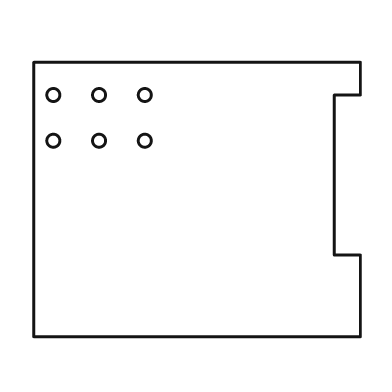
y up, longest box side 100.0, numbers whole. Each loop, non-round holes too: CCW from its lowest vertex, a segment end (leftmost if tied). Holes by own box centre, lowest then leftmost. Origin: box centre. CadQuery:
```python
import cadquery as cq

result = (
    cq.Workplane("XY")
    .moveTo(-50.0, -42.0)
    .lineTo(50.0, -42.0)
    .lineTo(50.0, -17.0)
    .lineTo(42.0, -17.0)
    .lineTo(42.0, 32.0)
    .lineTo(50.0, 32.0)
    .lineTo(50.0, 42.0)
    .lineTo(-50.0, 42.0)
    .close()
    .moveTo(-44.0, 18.0)
    .circle(2.0)
    .moveTo(-30.0, 18.0)
    .circle(2.0)
    .moveTo(-16.0, 18.0)
    .circle(2.0)
    .moveTo(-44.0, 32.0)
    .circle(2.0)
    .moveTo(-30.0, 32.0)
    .circle(2.0)
    .moveTo(-16.0, 32.0)
    .circle(2.0)
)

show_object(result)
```